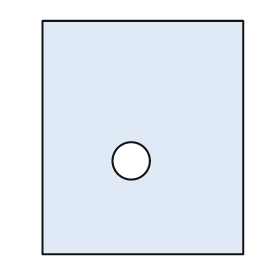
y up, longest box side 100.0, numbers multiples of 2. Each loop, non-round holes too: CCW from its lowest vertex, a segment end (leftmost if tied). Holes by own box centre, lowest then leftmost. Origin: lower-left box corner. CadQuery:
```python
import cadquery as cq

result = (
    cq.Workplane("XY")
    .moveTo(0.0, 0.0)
    .lineTo(86.0, 0.0)
    .lineTo(86.0, 100.0)
    .lineTo(0.0, 100.0)
    .close()
    .moveTo(38.0, 40.0)
    .circle(8.0)
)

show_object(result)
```